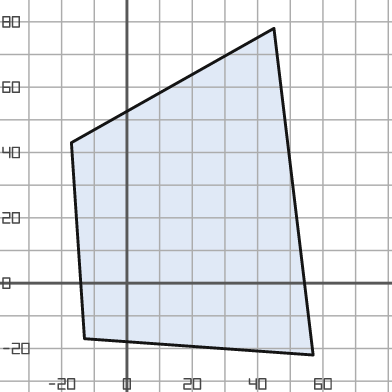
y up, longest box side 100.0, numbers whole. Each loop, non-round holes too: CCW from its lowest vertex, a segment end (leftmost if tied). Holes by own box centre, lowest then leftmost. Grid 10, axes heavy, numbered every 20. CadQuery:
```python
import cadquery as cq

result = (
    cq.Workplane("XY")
    .moveTo(57.0, -22.0)
    .lineTo(45.0, 78.0)
    .lineTo(-17.0, 43.0)
    .lineTo(-13.0, -17.0)
    .close()
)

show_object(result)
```